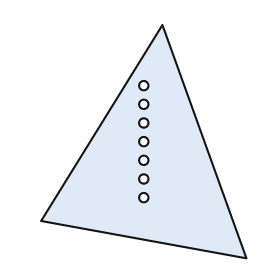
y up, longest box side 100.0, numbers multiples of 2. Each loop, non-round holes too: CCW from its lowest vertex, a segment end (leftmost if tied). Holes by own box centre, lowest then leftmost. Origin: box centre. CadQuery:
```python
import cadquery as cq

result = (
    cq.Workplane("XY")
    .moveTo(44.0, -50.0)
    .lineTo(8.0, 50.0)
    .lineTo(-44.0, -34.0)
    .close()
    .moveTo(0.0, -24.0)
    .circle(2.0)
    .moveTo(0.0, -16.0)
    .circle(2.0)
    .moveTo(0.0, -8.0)
    .circle(2.0)
    .moveTo(0.0, 0.0)
    .circle(2.0)
    .moveTo(0.0, 8.0)
    .circle(2.0)
    .moveTo(0.0, 16.0)
    .circle(2.0)
    .moveTo(0.0, 24.0)
    .circle(2.0)
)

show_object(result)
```